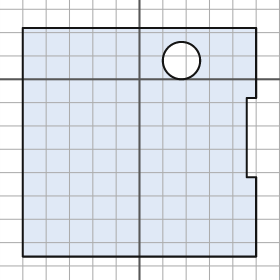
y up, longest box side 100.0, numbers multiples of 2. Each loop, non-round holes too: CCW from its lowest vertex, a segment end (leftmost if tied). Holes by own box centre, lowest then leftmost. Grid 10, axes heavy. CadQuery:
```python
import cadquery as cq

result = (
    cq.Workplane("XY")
    .moveTo(-50.0, -76.0)
    .lineTo(50.0, -76.0)
    .lineTo(50.0, -42.0)
    .lineTo(46.0, -42.0)
    .lineTo(46.0, -8.0)
    .lineTo(50.0, -8.0)
    .lineTo(50.0, 22.0)
    .lineTo(-50.0, 22.0)
    .close()
    .moveTo(18.0, 8.0)
    .circle(8.0)
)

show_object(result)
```